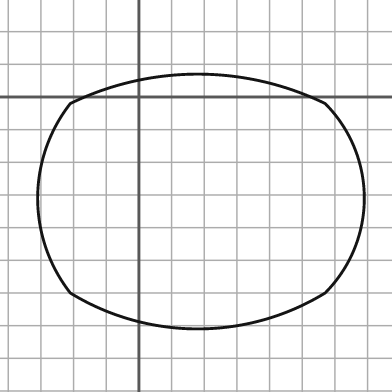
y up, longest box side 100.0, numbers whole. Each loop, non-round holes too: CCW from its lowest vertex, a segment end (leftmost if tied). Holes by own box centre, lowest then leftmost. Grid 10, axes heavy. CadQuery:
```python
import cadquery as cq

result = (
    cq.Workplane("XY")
    .moveTo(-21.0, -60.0)
    .threePointArc((18.0, -71.0), (57.0, -60.0))
    .threePointArc((69.0, -31.0), (57.0, -2.0))
    .threePointArc((18.0, 7.0), (-21.0, -2.0))
    .threePointArc((-31.0, -31.0), (-21.0, -60.0))
    .close()
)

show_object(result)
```